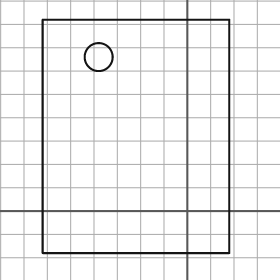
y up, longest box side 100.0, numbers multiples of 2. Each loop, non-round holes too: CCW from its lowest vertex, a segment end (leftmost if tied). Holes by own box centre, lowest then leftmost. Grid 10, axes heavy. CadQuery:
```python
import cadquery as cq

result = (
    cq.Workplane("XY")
    .moveTo(-62.0, -18.0)
    .lineTo(18.0, -18.0)
    .lineTo(18.0, 82.0)
    .lineTo(-62.0, 82.0)
    .close()
    .moveTo(-38.0, 66.0)
    .circle(6.0)
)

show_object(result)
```